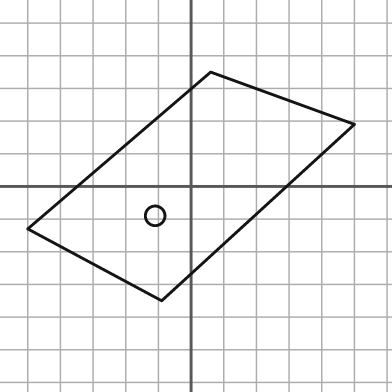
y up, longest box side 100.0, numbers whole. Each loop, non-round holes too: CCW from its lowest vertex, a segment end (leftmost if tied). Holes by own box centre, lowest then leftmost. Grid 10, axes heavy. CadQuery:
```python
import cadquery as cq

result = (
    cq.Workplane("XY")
    .moveTo(-9.0, -35.0)
    .lineTo(50.0, 19.0)
    .lineTo(6.0, 35.0)
    .lineTo(-50.0, -13.0)
    .close()
    .moveTo(-11.0, -9.0)
    .circle(3.0)
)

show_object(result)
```